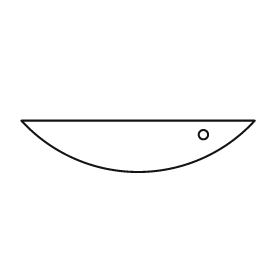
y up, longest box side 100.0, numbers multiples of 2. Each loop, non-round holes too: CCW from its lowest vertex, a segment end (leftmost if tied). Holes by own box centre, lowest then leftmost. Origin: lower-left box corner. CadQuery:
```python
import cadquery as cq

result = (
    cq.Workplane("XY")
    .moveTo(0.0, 22.0)
    .threePointArc((50.0, 0.0), (100.0, 22.0))
    .close()
    .moveTo(78.0, 16.0)
    .circle(2.0)
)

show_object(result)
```